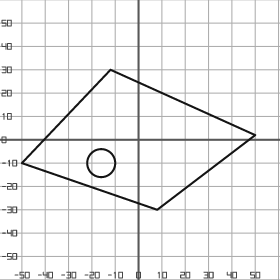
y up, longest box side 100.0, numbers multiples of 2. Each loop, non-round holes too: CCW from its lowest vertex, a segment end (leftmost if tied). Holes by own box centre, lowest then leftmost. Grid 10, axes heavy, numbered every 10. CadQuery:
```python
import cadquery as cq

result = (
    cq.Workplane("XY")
    .moveTo(8.0, -30.0)
    .lineTo(50.0, 2.0)
    .lineTo(-12.0, 30.0)
    .lineTo(-50.0, -10.0)
    .close()
    .moveTo(-16.0, -10.0)
    .circle(6.0)
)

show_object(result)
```